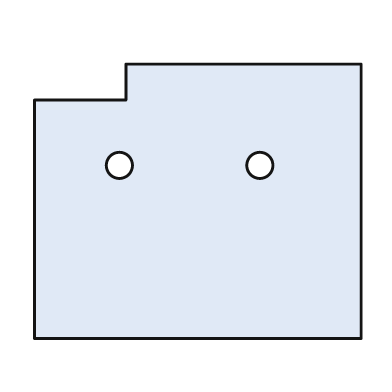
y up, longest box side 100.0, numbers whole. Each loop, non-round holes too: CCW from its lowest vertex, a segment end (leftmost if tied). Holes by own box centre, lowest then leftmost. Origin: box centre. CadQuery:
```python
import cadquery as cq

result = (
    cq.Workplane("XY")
    .moveTo(-50.0, -42.0)
    .lineTo(50.0, -42.0)
    .lineTo(50.0, 42.0)
    .lineTo(-22.0, 42.0)
    .lineTo(-22.0, 31.0)
    .lineTo(-50.0, 31.0)
    .close()
    .moveTo(-24.0, 11.0)
    .circle(4.0)
    .moveTo(19.0, 11.0)
    .circle(4.0)
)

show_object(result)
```